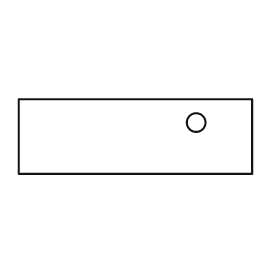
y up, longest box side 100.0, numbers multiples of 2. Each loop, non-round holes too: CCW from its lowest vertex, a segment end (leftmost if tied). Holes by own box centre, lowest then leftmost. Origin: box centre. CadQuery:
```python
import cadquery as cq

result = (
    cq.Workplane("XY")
    .moveTo(-50.0, -16.0)
    .lineTo(50.0, -16.0)
    .lineTo(50.0, 16.0)
    .lineTo(-50.0, 16.0)
    .close()
    .moveTo(26.0, 6.0)
    .circle(4.0)
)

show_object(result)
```